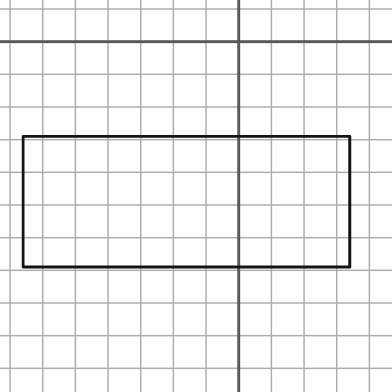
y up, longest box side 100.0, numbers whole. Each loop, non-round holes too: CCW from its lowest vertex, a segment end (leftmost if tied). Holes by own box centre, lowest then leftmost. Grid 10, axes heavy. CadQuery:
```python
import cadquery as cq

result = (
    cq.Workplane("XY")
    .moveTo(-66.0, -69.0)
    .lineTo(34.0, -69.0)
    .lineTo(34.0, -29.0)
    .lineTo(-66.0, -29.0)
    .close()
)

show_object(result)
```